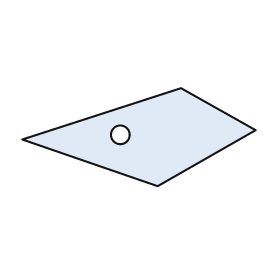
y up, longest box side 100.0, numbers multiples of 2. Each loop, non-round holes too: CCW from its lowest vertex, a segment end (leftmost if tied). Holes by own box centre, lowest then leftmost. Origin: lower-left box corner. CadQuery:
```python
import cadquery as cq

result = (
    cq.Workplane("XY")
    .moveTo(58.0, 0.0)
    .lineTo(100.0, 24.0)
    .lineTo(68.0, 42.0)
    .lineTo(0.0, 20.0)
    .close()
    .moveTo(42.0, 22.0)
    .circle(4.0)
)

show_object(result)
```